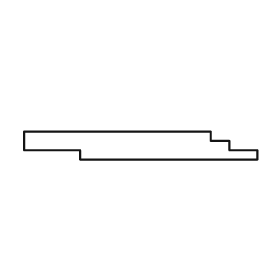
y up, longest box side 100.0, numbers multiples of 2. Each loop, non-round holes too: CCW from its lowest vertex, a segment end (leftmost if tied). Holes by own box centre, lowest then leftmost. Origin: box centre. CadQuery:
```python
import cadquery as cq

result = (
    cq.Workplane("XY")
    .moveTo(-26.0, -6.0)
    .lineTo(50.0, -6.0)
    .lineTo(50.0, -2.0)
    .lineTo(38.0, -2.0)
    .lineTo(38.0, 2.0)
    .lineTo(30.0, 2.0)
    .lineTo(30.0, 6.0)
    .lineTo(-50.0, 6.0)
    .lineTo(-50.0, -2.0)
    .lineTo(-26.0, -2.0)
    .close()
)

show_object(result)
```